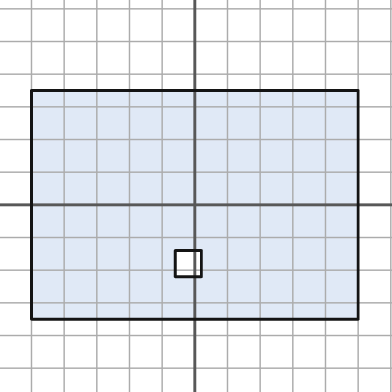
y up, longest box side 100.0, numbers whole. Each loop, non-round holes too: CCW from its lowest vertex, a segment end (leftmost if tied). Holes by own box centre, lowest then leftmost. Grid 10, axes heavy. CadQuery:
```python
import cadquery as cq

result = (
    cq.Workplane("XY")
    .moveTo(-50.0, -35.0)
    .lineTo(50.0, -35.0)
    .lineTo(50.0, 35.0)
    .lineTo(-50.0, 35.0)
    .close()
    .moveTo(-6.0, -22.0)
    .lineTo(2.0, -22.0)
    .lineTo(2.0, -14.0)
    .lineTo(-6.0, -14.0)
    .close()
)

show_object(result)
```